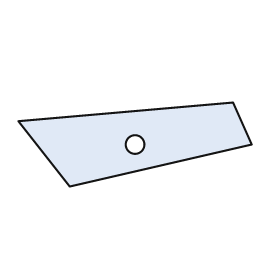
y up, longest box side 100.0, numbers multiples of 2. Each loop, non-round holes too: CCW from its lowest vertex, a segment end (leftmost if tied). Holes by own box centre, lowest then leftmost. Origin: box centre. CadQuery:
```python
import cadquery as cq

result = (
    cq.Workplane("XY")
    .moveTo(-28.0, -18.0)
    .lineTo(50.0, 0.0)
    .lineTo(42.0, 18.0)
    .lineTo(-50.0, 10.0)
    .close()
    .moveTo(0.0, 0.0)
    .circle(4.0)
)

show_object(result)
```